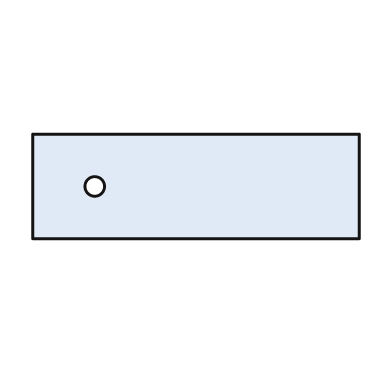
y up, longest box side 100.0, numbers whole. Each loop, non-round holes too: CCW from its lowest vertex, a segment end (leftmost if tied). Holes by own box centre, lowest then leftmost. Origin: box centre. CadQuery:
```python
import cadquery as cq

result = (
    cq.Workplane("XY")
    .moveTo(-50.0, -16.0)
    .lineTo(50.0, -16.0)
    .lineTo(50.0, 16.0)
    .lineTo(-50.0, 16.0)
    .close()
    .moveTo(-31.0, 0.0)
    .circle(3.0)
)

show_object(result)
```